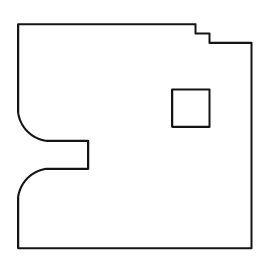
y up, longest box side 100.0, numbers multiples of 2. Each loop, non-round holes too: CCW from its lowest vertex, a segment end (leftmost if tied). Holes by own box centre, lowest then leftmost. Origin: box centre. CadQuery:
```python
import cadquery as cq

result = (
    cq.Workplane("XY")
    .moveTo(-50.0, -48.0)
    .lineTo(50.0, -48.0)
    .lineTo(50.0, 40.0)
    .lineTo(32.0, 40.0)
    .lineTo(32.0, 44.0)
    .lineTo(26.0, 44.0)
    .lineTo(26.0, 48.0)
    .lineTo(-50.0, 48.0)
    .lineTo(-50.0, 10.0)
    .threePointArc((-46.0, 2.0), (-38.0, -2.0))
    .lineTo(-20.0, -2.0)
    .lineTo(-20.0, -14.0)
    .lineTo(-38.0, -14.0)
    .threePointArc((-46.0, -18.0), (-50.0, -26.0))
    .close()
    .moveTo(16.0, 4.0)
    .lineTo(32.0, 4.0)
    .lineTo(32.0, 20.0)
    .lineTo(16.0, 20.0)
    .close()
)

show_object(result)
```